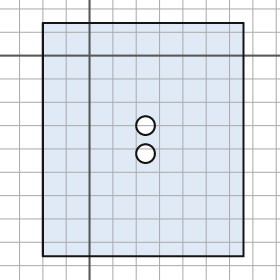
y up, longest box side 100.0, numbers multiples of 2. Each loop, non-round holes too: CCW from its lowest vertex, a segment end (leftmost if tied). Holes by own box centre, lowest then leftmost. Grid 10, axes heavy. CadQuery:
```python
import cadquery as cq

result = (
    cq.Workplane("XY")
    .moveTo(-20.0, -86.0)
    .lineTo(66.0, -86.0)
    .lineTo(66.0, 14.0)
    .lineTo(-20.0, 14.0)
    .close()
    .moveTo(24.0, -42.0)
    .circle(4.0)
    .moveTo(24.0, -30.0)
    .circle(4.0)
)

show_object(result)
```